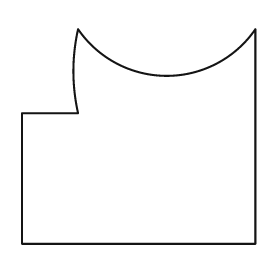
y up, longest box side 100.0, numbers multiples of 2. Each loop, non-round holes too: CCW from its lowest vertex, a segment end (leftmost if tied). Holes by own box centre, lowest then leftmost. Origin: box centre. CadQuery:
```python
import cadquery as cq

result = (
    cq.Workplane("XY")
    .moveTo(-50.0, -46.0)
    .lineTo(50.0, -46.0)
    .lineTo(50.0, 46.0)
    .threePointArc((12.0, 26.0), (-26.0, 46.0))
    .threePointArc((-28.0, 28.0), (-26.0, 10.0))
    .lineTo(-50.0, 10.0)
    .close()
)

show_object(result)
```